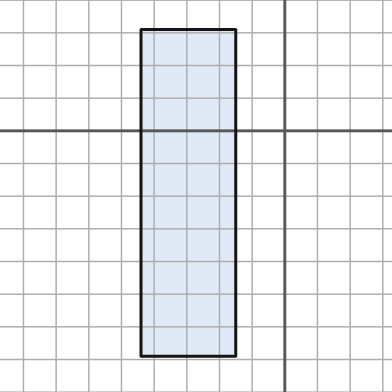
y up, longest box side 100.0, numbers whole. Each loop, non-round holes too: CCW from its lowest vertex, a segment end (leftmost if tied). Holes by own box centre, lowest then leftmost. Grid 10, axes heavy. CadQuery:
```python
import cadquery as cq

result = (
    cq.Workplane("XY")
    .moveTo(-44.0, -69.0)
    .lineTo(-15.0, -69.0)
    .lineTo(-15.0, 31.0)
    .lineTo(-44.0, 31.0)
    .close()
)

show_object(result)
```